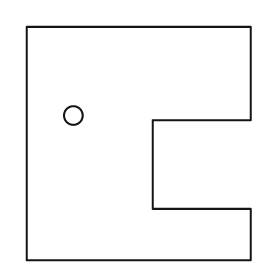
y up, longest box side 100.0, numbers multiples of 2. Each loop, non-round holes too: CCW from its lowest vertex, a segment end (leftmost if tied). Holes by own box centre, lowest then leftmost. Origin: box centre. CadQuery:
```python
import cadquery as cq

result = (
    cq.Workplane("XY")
    .moveTo(-48.0, -50.0)
    .lineTo(48.0, -50.0)
    .lineTo(48.0, -28.0)
    .lineTo(6.0, -28.0)
    .lineTo(6.0, 10.0)
    .lineTo(48.0, 10.0)
    .lineTo(48.0, 50.0)
    .lineTo(-48.0, 50.0)
    .close()
    .moveTo(-28.0, 12.0)
    .circle(4.0)
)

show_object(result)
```